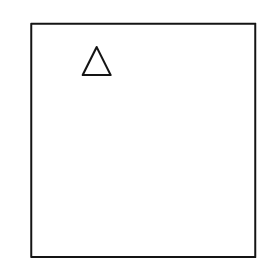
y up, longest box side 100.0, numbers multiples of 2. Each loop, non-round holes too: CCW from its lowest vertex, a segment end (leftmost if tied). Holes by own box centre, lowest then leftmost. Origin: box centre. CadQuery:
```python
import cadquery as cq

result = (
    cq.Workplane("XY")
    .moveTo(-48.0, -50.0)
    .lineTo(48.0, -50.0)
    .lineTo(48.0, 50.0)
    .lineTo(-48.0, 50.0)
    .close()
    .moveTo(-26.0, 28.0)
    .lineTo(-14.0, 28.0)
    .lineTo(-20.0, 40.0)
    .close()
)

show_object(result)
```